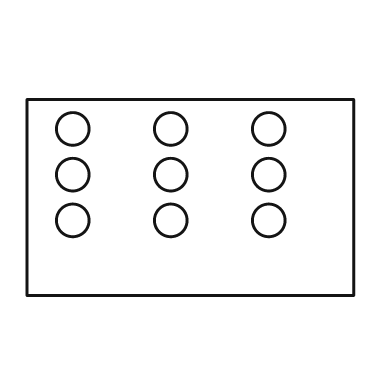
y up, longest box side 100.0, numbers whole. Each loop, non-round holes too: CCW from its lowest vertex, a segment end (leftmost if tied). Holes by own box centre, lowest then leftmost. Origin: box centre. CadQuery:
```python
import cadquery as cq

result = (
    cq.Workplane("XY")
    .moveTo(-50.0, -30.0)
    .lineTo(50.0, -30.0)
    .lineTo(50.0, 30.0)
    .lineTo(-50.0, 30.0)
    .close()
    .moveTo(-36.0, -7.0)
    .circle(5.0)
    .moveTo(-6.0, -7.0)
    .circle(5.0)
    .moveTo(24.0, -7.0)
    .circle(5.0)
    .moveTo(-36.0, 7.0)
    .circle(5.0)
    .moveTo(-6.0, 7.0)
    .circle(5.0)
    .moveTo(24.0, 7.0)
    .circle(5.0)
    .moveTo(-36.0, 21.0)
    .circle(5.0)
    .moveTo(-6.0, 21.0)
    .circle(5.0)
    .moveTo(24.0, 21.0)
    .circle(5.0)
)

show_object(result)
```